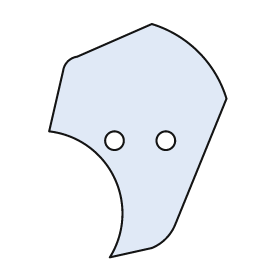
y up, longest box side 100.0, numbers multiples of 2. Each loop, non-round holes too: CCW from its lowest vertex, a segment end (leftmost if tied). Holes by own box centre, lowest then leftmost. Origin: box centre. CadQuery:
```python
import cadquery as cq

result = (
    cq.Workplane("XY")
    .moveTo(-12.0, -50.0)
    .lineTo(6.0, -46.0)
    .threePointArc((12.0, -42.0), (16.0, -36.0))
    .lineTo(38.0, 18.0)
    .threePointArc((26.0, 38.0), (6.0, 50.0))
    .lineTo(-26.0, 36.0)
    .threePointArc((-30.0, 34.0), (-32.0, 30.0))
    .lineTo(-38.0, 4.0)
    .threePointArc((-10.0, -16.0), (-12.0, -50.0))
    .close()
    .moveTo(-10.0, 0.0)
    .circle(4.0)
    .moveTo(12.0, 0.0)
    .circle(4.0)
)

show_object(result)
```